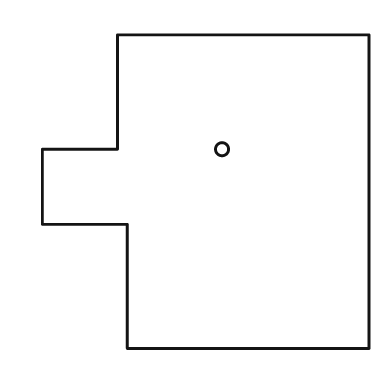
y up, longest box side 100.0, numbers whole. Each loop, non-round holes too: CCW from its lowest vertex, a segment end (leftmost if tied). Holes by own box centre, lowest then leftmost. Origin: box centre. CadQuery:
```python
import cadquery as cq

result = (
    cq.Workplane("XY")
    .moveTo(-24.0, -48.0)
    .lineTo(50.0, -48.0)
    .lineTo(50.0, 48.0)
    .lineTo(-27.0, 48.0)
    .lineTo(-27.0, 13.0)
    .lineTo(-50.0, 13.0)
    .lineTo(-50.0, -10.0)
    .lineTo(-24.0, -10.0)
    .close()
    .moveTo(5.0, 13.0)
    .circle(2.0)
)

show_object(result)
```